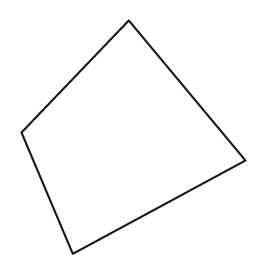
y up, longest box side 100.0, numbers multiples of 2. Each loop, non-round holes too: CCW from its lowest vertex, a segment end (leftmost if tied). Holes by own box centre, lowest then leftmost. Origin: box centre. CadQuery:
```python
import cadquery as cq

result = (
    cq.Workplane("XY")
    .moveTo(-26.0, -50.0)
    .lineTo(48.0, -10.0)
    .lineTo(-2.0, 50.0)
    .lineTo(-48.0, 2.0)
    .close()
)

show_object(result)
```